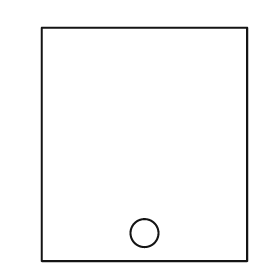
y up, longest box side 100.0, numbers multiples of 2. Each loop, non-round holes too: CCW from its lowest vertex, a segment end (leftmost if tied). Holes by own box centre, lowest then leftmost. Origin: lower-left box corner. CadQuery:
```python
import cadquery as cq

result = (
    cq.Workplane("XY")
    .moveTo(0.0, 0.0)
    .lineTo(88.0, 0.0)
    .lineTo(88.0, 100.0)
    .lineTo(0.0, 100.0)
    .close()
    .moveTo(44.0, 12.0)
    .circle(6.0)
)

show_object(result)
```